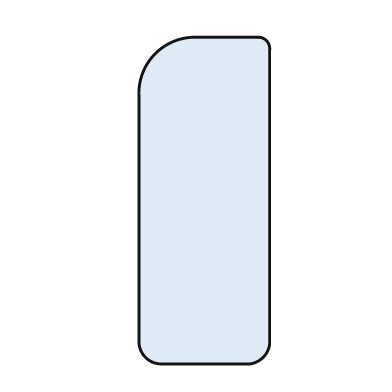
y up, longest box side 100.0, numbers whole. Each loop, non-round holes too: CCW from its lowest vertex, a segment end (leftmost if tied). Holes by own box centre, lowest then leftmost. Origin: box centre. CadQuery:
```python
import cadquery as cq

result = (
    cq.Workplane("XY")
    .moveTo(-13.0, -50.0)
    .lineTo(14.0, -50.0)
    .threePointArc((18.0, -48.0), (20.0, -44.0))
    .lineTo(20.0, 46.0)
    .threePointArc((19.0, 49.0), (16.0, 50.0))
    .lineTo(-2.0, 50.0)
    .threePointArc((-15.0, 45.0), (-20.0, 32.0))
    .lineTo(-20.0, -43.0)
    .threePointArc((-18.0, -48.0), (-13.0, -50.0))
    .close()
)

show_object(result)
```